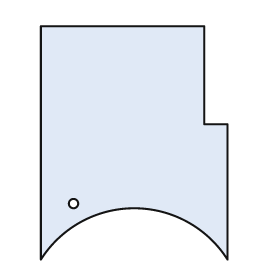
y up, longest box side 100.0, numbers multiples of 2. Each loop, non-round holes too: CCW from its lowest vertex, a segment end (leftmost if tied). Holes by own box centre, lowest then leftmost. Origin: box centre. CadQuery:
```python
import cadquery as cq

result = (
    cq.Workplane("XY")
    .moveTo(-40.0, -50.0)
    .threePointArc((0.0, -28.0), (40.0, -50.0))
    .lineTo(40.0, 8.0)
    .lineTo(30.0, 8.0)
    .lineTo(30.0, 50.0)
    .lineTo(-40.0, 50.0)
    .close()
    .moveTo(-26.0, -26.0)
    .circle(2.0)
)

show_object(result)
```